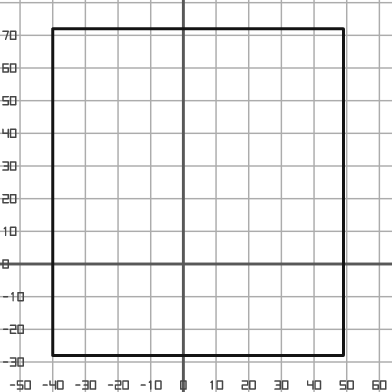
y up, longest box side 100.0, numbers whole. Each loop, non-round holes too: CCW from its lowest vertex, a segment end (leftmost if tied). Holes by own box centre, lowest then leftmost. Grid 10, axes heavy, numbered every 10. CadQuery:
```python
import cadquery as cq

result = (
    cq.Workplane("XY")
    .moveTo(-40.0, -28.0)
    .lineTo(49.0, -28.0)
    .lineTo(49.0, 72.0)
    .lineTo(-40.0, 72.0)
    .close()
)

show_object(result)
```